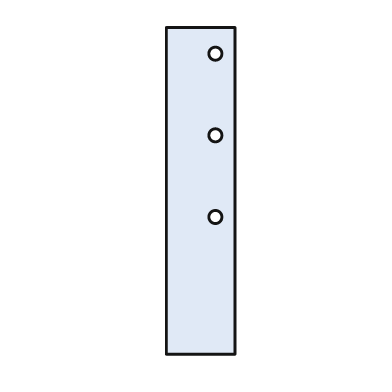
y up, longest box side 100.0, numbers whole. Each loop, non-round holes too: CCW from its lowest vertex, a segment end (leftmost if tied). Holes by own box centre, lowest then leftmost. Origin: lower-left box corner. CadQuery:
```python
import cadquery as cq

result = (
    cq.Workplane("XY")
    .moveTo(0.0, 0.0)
    .lineTo(21.0, 0.0)
    .lineTo(21.0, 100.0)
    .lineTo(0.0, 100.0)
    .close()
    .moveTo(15.0, 42.0)
    .circle(2.0)
    .moveTo(15.0, 67.0)
    .circle(2.0)
    .moveTo(15.0, 92.0)
    .circle(2.0)
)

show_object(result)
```